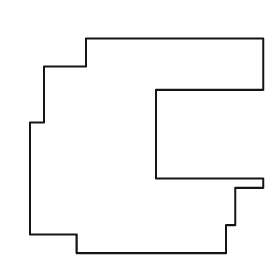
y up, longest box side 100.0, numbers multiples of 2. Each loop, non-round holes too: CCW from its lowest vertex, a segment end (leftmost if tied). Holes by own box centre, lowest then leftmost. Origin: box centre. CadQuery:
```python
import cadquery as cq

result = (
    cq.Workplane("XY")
    .moveTo(-30.0, -46.0)
    .lineTo(34.0, -46.0)
    .lineTo(34.0, -34.0)
    .lineTo(38.0, -34.0)
    .lineTo(38.0, -18.0)
    .lineTo(50.0, -18.0)
    .lineTo(50.0, -14.0)
    .lineTo(4.0, -14.0)
    .lineTo(4.0, 24.0)
    .lineTo(50.0, 24.0)
    .lineTo(50.0, 46.0)
    .lineTo(-26.0, 46.0)
    .lineTo(-26.0, 34.0)
    .lineTo(-44.0, 34.0)
    .lineTo(-44.0, 10.0)
    .lineTo(-50.0, 10.0)
    .lineTo(-50.0, -38.0)
    .lineTo(-30.0, -38.0)
    .close()
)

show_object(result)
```